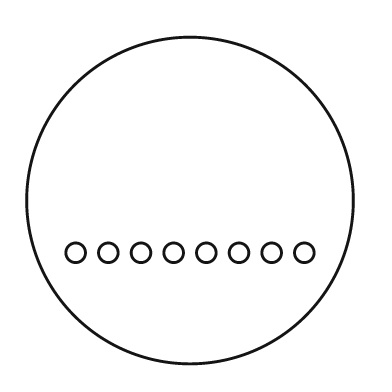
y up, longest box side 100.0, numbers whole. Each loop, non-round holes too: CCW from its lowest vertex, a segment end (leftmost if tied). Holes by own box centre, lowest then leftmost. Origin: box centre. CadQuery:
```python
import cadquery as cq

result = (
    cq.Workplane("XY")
    .moveTo(0.0, 0.0)
    .circle(50.0)
    .moveTo(-35.0, -16.0)
    .circle(3.0)
    .moveTo(-25.0, -16.0)
    .circle(3.0)
    .moveTo(-15.0, -16.0)
    .circle(3.0)
    .moveTo(-5.0, -16.0)
    .circle(3.0)
    .moveTo(5.0, -16.0)
    .circle(3.0)
    .moveTo(15.0, -16.0)
    .circle(3.0)
    .moveTo(25.0, -16.0)
    .circle(3.0)
    .moveTo(35.0, -16.0)
    .circle(3.0)
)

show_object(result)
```